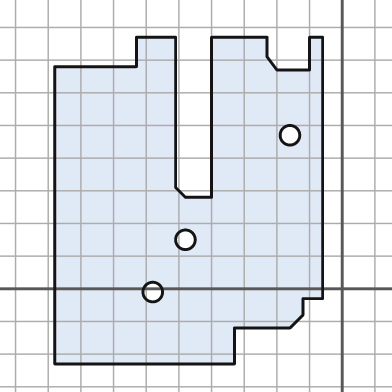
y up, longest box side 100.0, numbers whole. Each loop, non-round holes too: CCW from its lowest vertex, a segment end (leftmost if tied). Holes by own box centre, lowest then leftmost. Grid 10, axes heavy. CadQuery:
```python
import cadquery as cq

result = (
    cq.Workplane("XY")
    .moveTo(-88.0, -23.0)
    .lineTo(-33.0, -23.0)
    .lineTo(-33.0, -12.0)
    .lineTo(-16.0, -12.0)
    .lineTo(-12.0, -8.0)
    .lineTo(-12.0, -3.0)
    .lineTo(-6.0, -3.0)
    .lineTo(-6.0, 77.0)
    .lineTo(-10.0, 77.0)
    .lineTo(-10.0, 67.0)
    .lineTo(-20.0, 67.0)
    .lineTo(-23.0, 71.0)
    .lineTo(-23.0, 77.0)
    .lineTo(-40.0, 77.0)
    .lineTo(-40.0, 28.0)
    .lineTo(-48.0, 28.0)
    .lineTo(-51.0, 31.0)
    .lineTo(-51.0, 77.0)
    .lineTo(-63.0, 77.0)
    .lineTo(-63.0, 68.0)
    .lineTo(-88.0, 68.0)
    .close()
    .moveTo(-58.0, -1.0)
    .circle(3.0)
    .moveTo(-48.0, 15.0)
    .circle(3.0)
    .moveTo(-16.0, 47.0)
    .circle(3.0)
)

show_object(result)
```